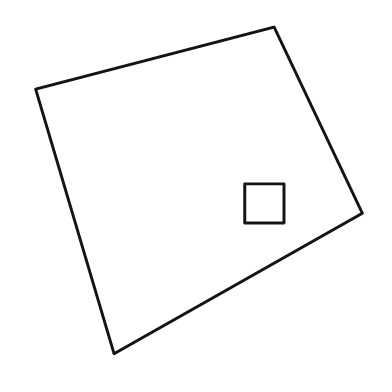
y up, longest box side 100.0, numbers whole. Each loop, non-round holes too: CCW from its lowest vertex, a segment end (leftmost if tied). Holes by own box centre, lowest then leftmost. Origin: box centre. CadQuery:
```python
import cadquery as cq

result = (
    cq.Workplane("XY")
    .moveTo(-26.0, -50.0)
    .lineTo(50.0, -7.0)
    .lineTo(23.0, 50.0)
    .lineTo(-50.0, 31.0)
    .close()
    .moveTo(14.0, -10.0)
    .lineTo(26.0, -10.0)
    .lineTo(26.0, 2.0)
    .lineTo(14.0, 2.0)
    .close()
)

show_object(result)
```